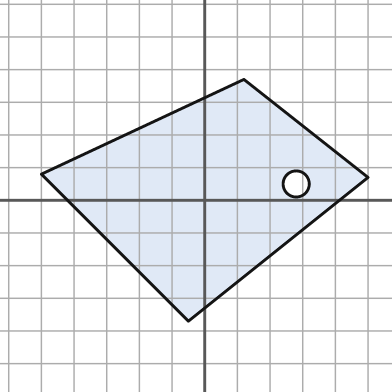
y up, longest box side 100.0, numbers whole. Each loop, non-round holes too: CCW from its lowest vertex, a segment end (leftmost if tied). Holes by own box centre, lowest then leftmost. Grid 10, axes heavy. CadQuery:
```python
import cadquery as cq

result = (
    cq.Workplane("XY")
    .moveTo(-5.0, -37.0)
    .lineTo(50.0, 7.0)
    .lineTo(12.0, 37.0)
    .lineTo(-50.0, 8.0)
    .close()
    .moveTo(28.0, 5.0)
    .circle(4.0)
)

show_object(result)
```